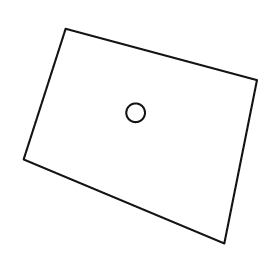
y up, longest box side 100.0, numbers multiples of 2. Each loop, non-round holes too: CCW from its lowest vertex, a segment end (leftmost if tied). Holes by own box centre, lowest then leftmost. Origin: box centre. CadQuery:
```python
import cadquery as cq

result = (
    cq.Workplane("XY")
    .moveTo(36.0, -46.0)
    .lineTo(50.0, 24.0)
    .lineTo(-32.0, 46.0)
    .lineTo(-50.0, -10.0)
    .close()
    .moveTo(-2.0, 10.0)
    .circle(4.0)
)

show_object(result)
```